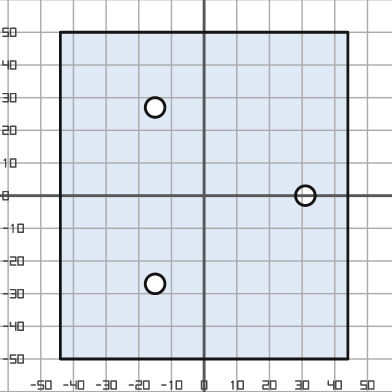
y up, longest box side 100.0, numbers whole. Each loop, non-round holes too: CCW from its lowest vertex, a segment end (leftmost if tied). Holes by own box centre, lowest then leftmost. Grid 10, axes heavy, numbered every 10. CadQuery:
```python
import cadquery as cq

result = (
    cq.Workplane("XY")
    .moveTo(-44.0, -50.0)
    .lineTo(44.0, -50.0)
    .lineTo(44.0, 50.0)
    .lineTo(-44.0, 50.0)
    .close()
    .moveTo(-15.0, -27.0)
    .circle(3.0)
    .moveTo(31.0, 0.0)
    .circle(3.0)
    .moveTo(-15.0, 27.0)
    .circle(3.0)
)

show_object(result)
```